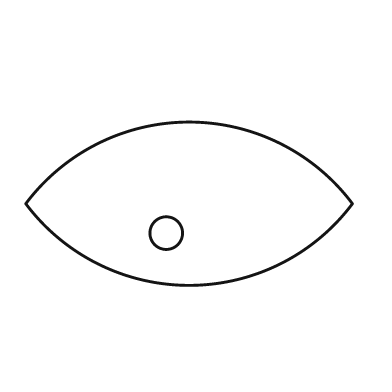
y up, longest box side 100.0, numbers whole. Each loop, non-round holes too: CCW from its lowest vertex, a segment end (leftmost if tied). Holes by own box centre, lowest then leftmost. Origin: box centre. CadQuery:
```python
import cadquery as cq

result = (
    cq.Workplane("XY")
    .moveTo(-50.0, 0.0)
    .threePointArc((0.0, -25.0), (50.0, 0.0))
    .threePointArc((0.0, 25.0), (-50.0, 0.0))
    .close()
    .moveTo(-7.0, -9.0)
    .circle(5.0)
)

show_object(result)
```